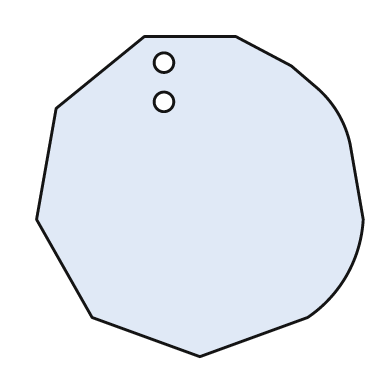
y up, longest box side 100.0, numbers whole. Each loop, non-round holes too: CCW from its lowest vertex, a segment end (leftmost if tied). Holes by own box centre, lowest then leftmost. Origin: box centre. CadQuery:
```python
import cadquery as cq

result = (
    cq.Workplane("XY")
    .moveTo(0.0, -49.0)
    .lineTo(33.0, -37.0)
    .threePointArc((45.0, -24.0), (50.0, -7.0))
    .lineTo(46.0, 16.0)
    .threePointArc((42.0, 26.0), (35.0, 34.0))
    .lineTo(28.0, 40.0)
    .lineTo(11.0, 49.0)
    .lineTo(-17.0, 49.0)
    .lineTo(-44.0, 27.0)
    .lineTo(-50.0, -7.0)
    .lineTo(-33.0, -37.0)
    .close()
    .moveTo(-11.0, 29.0)
    .circle(3.0)
    .moveTo(-11.0, 41.0)
    .circle(3.0)
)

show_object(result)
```